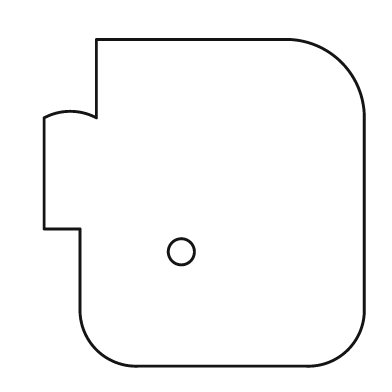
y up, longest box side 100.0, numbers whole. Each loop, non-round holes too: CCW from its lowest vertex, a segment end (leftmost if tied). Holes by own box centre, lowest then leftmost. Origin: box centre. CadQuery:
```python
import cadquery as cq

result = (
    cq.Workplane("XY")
    .moveTo(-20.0, -50.0)
    .lineTo(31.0, -50.0)
    .threePointArc((44.0, -45.0), (49.0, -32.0))
    .lineTo(49.0, 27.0)
    .threePointArc((42.0, 43.0), (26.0, 50.0))
    .lineTo(-33.0, 50.0)
    .lineTo(-33.0, 26.0)
    .threePointArc((-41.0, 28.0), (-49.0, 26.0))
    .lineTo(-49.0, -8.0)
    .lineTo(-38.0, -8.0)
    .lineTo(-38.0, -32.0)
    .threePointArc((-33.0, -45.0), (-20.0, -50.0))
    .close()
    .moveTo(-7.0, -15.0)
    .circle(4.0)
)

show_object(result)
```